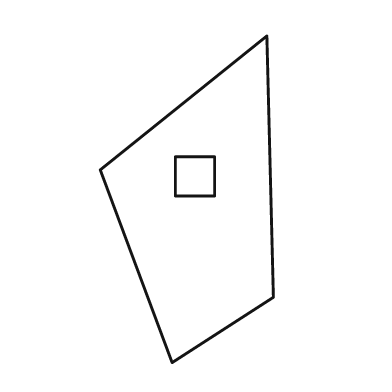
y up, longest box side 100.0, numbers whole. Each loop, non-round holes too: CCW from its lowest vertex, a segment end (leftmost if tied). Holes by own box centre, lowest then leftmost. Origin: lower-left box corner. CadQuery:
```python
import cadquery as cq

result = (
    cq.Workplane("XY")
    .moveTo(22.0, 0.0)
    .lineTo(53.0, 20.0)
    .lineTo(51.0, 100.0)
    .lineTo(0.0, 59.0)
    .close()
    .moveTo(23.0, 51.0)
    .lineTo(35.0, 51.0)
    .lineTo(35.0, 63.0)
    .lineTo(23.0, 63.0)
    .close()
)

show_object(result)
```